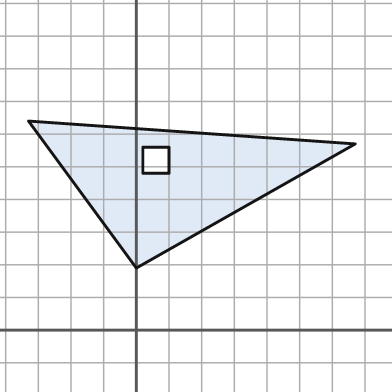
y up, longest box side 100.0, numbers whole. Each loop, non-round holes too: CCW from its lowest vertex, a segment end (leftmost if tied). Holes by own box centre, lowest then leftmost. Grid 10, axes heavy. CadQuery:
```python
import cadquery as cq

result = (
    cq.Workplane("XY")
    .moveTo(0.0, 19.0)
    .lineTo(67.0, 57.0)
    .lineTo(-33.0, 64.0)
    .close()
    .moveTo(2.0, 48.0)
    .lineTo(10.0, 48.0)
    .lineTo(10.0, 56.0)
    .lineTo(2.0, 56.0)
    .close()
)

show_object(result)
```